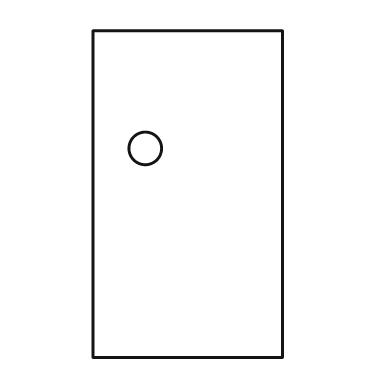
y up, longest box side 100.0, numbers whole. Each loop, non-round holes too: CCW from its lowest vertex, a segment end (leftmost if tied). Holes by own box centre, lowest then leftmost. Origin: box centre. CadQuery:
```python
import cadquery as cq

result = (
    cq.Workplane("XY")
    .moveTo(-29.0, -50.0)
    .lineTo(29.0, -50.0)
    .lineTo(29.0, 50.0)
    .lineTo(-29.0, 50.0)
    .close()
    .moveTo(-13.0, 14.0)
    .circle(5.0)
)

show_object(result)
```